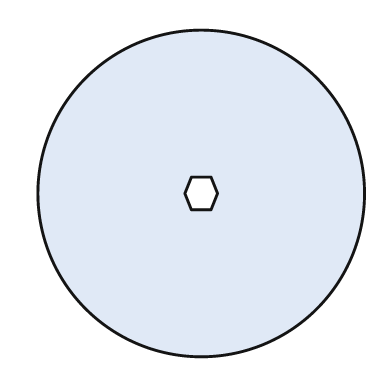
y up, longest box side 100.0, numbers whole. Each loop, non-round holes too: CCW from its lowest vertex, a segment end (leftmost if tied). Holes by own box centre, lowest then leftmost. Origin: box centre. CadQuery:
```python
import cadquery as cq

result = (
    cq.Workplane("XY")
    .moveTo(0.0, 0.0)
    .circle(50.0)
    .moveTo(-3.0, -5.0)
    .lineTo(3.0, -5.0)
    .lineTo(5.0, 0.0)
    .lineTo(3.0, 5.0)
    .lineTo(-3.0, 5.0)
    .lineTo(-5.0, 0.0)
    .close()
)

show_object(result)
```